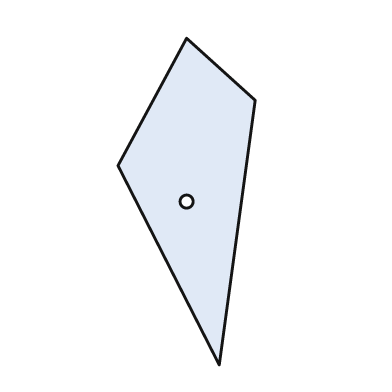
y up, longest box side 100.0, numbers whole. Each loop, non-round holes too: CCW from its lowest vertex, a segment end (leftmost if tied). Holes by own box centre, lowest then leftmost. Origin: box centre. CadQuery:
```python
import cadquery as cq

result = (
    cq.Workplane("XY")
    .moveTo(10.0, -50.0)
    .lineTo(21.0, 31.0)
    .lineTo(0.0, 50.0)
    .lineTo(-21.0, 11.0)
    .close()
    .moveTo(0.0, 0.0)
    .circle(2.0)
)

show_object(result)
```